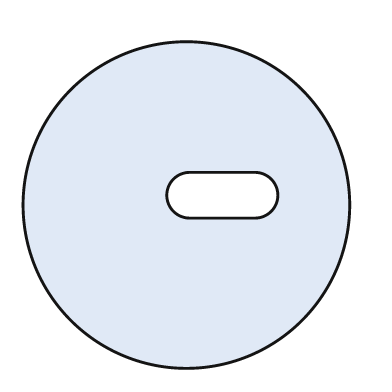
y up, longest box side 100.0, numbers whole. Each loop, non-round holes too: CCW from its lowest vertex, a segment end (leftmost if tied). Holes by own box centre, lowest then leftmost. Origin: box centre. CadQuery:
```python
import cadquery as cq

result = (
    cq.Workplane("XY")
    .moveTo(0.0, 0.0)
    .circle(50.0)
    .moveTo(1.0, -4.0)
    .lineTo(21.0, -4.0)
    .threePointArc((28.0, 3.0), (21.0, 10.0))
    .lineTo(1.0, 10.0)
    .threePointArc((-6.0, 3.0), (1.0, -4.0))
    .close()
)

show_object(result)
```